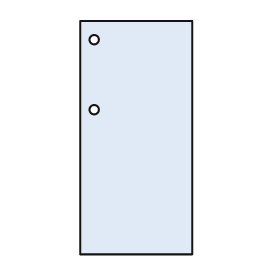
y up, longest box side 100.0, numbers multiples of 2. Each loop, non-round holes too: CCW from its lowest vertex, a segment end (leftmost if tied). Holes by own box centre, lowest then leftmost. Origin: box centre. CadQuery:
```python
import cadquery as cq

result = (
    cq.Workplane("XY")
    .moveTo(-24.0, -50.0)
    .lineTo(24.0, -50.0)
    .lineTo(24.0, 50.0)
    .lineTo(-24.0, 50.0)
    .close()
    .moveTo(-18.0, 12.0)
    .circle(2.0)
    .moveTo(-18.0, 42.0)
    .circle(2.0)
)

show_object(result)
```